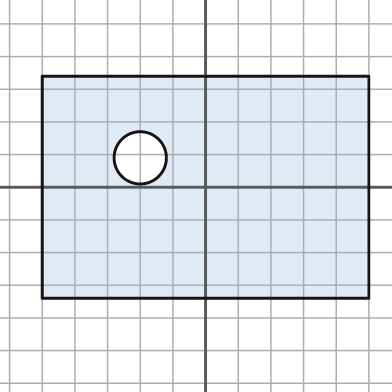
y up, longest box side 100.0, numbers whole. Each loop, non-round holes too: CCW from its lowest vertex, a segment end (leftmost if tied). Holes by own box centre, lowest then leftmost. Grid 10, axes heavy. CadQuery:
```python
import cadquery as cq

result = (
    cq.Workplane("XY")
    .moveTo(-50.0, -34.0)
    .lineTo(50.0, -34.0)
    .lineTo(50.0, 34.0)
    .lineTo(-50.0, 34.0)
    .close()
    .moveTo(-20.0, 9.0)
    .circle(8.0)
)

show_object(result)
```